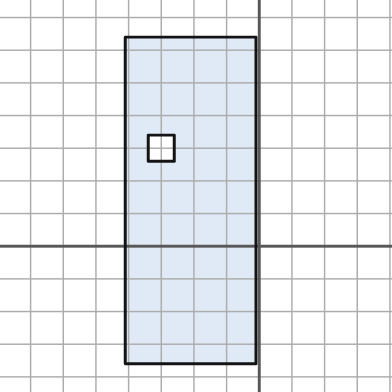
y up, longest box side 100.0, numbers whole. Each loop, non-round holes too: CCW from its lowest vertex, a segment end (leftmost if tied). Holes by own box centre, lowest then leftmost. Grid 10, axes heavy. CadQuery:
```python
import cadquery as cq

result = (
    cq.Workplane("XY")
    .moveTo(-41.0, -36.0)
    .lineTo(-1.0, -36.0)
    .lineTo(-1.0, 64.0)
    .lineTo(-41.0, 64.0)
    .close()
    .moveTo(-34.0, 26.0)
    .lineTo(-26.0, 26.0)
    .lineTo(-26.0, 34.0)
    .lineTo(-34.0, 34.0)
    .close()
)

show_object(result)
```